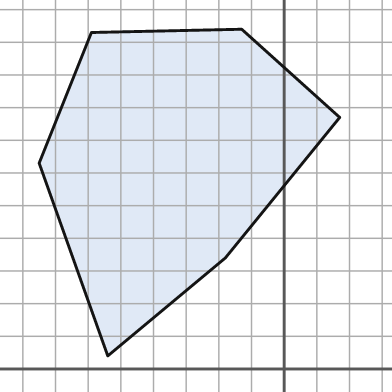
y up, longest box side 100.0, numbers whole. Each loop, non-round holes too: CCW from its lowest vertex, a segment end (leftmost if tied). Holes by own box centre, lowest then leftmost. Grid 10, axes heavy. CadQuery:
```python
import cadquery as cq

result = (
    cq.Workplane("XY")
    .moveTo(-54.0, 4.0)
    .lineTo(-18.0, 34.0)
    .lineTo(17.0, 77.0)
    .lineTo(-13.0, 104.0)
    .lineTo(-59.0, 103.0)
    .lineTo(-75.0, 63.0)
    .close()
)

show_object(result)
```